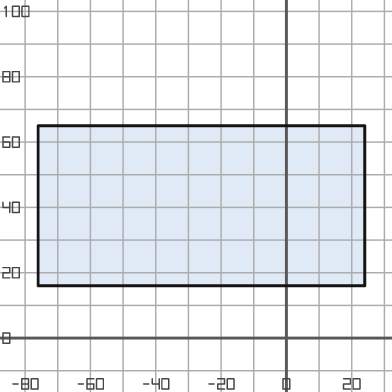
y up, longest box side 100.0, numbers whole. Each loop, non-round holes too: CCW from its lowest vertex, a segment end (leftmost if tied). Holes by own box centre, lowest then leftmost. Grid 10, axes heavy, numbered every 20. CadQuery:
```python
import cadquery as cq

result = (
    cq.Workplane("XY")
    .moveTo(-76.0, 16.0)
    .lineTo(24.0, 16.0)
    .lineTo(24.0, 65.0)
    .lineTo(-76.0, 65.0)
    .close()
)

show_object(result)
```